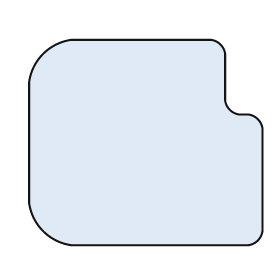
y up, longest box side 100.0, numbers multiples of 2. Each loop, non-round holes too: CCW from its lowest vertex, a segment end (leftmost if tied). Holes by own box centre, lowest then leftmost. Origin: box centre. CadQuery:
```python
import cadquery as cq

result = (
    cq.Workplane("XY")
    .moveTo(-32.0, -44.0)
    .lineTo(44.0, -44.0)
    .threePointArc((48.0, -42.0), (50.0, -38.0))
    .lineTo(50.0, 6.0)
    .threePointArc((48.0, 10.0), (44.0, 12.0))
    .lineTo(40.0, 12.0)
    .threePointArc((36.0, 14.0), (34.0, 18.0))
    .lineTo(34.0, 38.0)
    .threePointArc((32.0, 42.0), (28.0, 44.0))
    .lineTo(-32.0, 44.0)
    .threePointArc((-44.0, 38.0), (-50.0, 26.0))
    .lineTo(-50.0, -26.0)
    .threePointArc((-44.0, -38.0), (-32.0, -44.0))
    .close()
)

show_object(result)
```